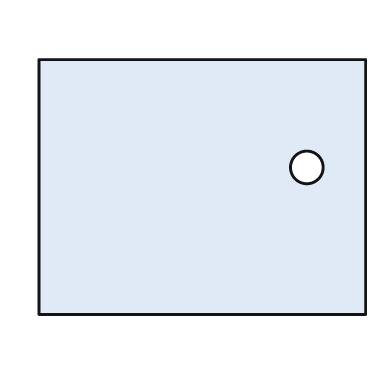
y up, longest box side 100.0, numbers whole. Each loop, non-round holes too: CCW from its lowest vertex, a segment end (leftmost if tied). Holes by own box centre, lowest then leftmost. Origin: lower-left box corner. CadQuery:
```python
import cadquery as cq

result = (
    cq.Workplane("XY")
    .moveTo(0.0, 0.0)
    .lineTo(100.0, 0.0)
    .lineTo(100.0, 78.0)
    .lineTo(0.0, 78.0)
    .close()
    .moveTo(82.0, 45.0)
    .circle(5.0)
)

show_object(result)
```